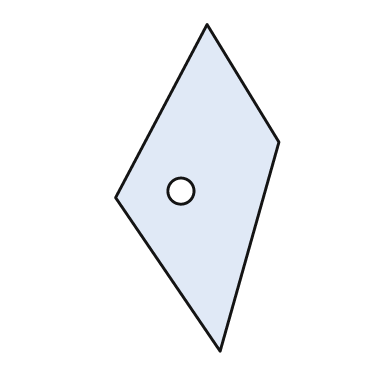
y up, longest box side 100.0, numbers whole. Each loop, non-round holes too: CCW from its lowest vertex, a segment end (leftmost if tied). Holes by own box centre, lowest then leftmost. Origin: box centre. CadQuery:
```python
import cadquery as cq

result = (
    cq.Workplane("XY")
    .moveTo(7.0, -50.0)
    .lineTo(25.0, 14.0)
    .lineTo(3.0, 50.0)
    .lineTo(-25.0, -3.0)
    .close()
    .moveTo(-5.0, -1.0)
    .circle(4.0)
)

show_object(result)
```